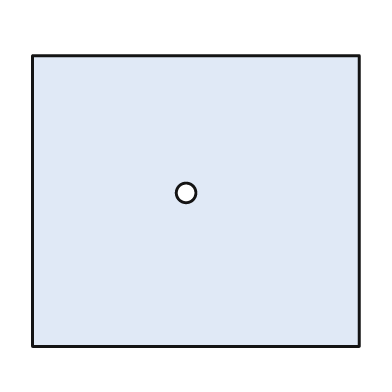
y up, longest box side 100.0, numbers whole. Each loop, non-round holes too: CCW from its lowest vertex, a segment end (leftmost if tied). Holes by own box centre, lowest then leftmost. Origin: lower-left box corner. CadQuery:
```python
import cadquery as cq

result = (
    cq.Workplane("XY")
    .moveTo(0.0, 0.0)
    .lineTo(100.0, 0.0)
    .lineTo(100.0, 89.0)
    .lineTo(0.0, 89.0)
    .close()
    .moveTo(47.0, 47.0)
    .circle(3.0)
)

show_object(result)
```